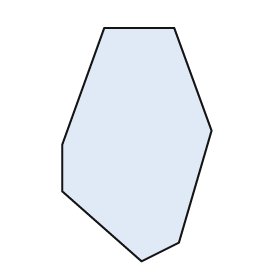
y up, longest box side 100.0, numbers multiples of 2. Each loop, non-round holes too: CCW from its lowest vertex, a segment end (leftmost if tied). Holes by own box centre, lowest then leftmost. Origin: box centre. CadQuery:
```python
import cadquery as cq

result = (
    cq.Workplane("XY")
    .moveTo(2.0, -50.0)
    .lineTo(18.0, -42.0)
    .lineTo(32.0, 6.0)
    .lineTo(16.0, 50.0)
    .lineTo(-14.0, 50.0)
    .lineTo(-32.0, 0.0)
    .lineTo(-32.0, -20.0)
    .close()
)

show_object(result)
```